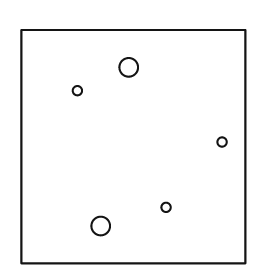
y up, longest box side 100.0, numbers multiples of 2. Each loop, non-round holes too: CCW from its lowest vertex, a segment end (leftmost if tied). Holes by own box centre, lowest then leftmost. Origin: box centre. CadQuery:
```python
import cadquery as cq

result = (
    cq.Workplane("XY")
    .moveTo(-48.0, -50.0)
    .lineTo(48.0, -50.0)
    .lineTo(48.0, 50.0)
    .lineTo(-48.0, 50.0)
    .close()
    .moveTo(-14.0, -34.0)
    .circle(4.0)
    .moveTo(14.0, -26.0)
    .circle(2.0)
    .moveTo(38.0, 2.0)
    .circle(2.0)
    .moveTo(-24.0, 24.0)
    .circle(2.0)
    .moveTo(-2.0, 34.0)
    .circle(4.0)
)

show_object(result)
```